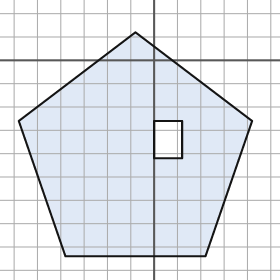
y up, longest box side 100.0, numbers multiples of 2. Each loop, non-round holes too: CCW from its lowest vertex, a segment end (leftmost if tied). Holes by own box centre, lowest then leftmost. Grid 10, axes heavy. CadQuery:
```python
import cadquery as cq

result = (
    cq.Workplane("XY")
    .moveTo(-38.0, -84.0)
    .lineTo(22.0, -84.0)
    .lineTo(42.0, -26.0)
    .lineTo(-8.0, 12.0)
    .lineTo(-58.0, -26.0)
    .close()
    .moveTo(0.0, -42.0)
    .lineTo(12.0, -42.0)
    .lineTo(12.0, -26.0)
    .lineTo(0.0, -26.0)
    .close()
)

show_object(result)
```